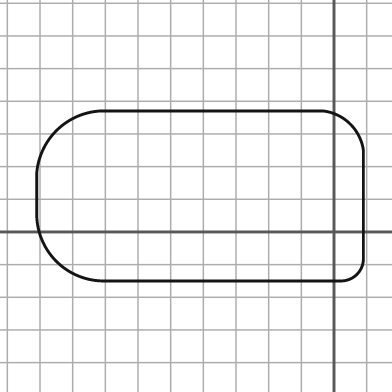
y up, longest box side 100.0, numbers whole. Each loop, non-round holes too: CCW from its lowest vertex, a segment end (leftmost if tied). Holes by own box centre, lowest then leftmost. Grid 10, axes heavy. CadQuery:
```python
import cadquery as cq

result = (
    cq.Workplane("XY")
    .moveTo(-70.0, -15.0)
    .lineTo(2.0, -15.0)
    .threePointArc((7.0, -13.0), (9.0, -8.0))
    .lineTo(9.0, 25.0)
    .threePointArc((5.0, 33.0), (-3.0, 37.0))
    .lineTo(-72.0, 37.0)
    .threePointArc((-85.0, 31.0), (-91.0, 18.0))
    .lineTo(-91.0, 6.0)
    .threePointArc((-85.0, -9.0), (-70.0, -15.0))
    .close()
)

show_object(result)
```